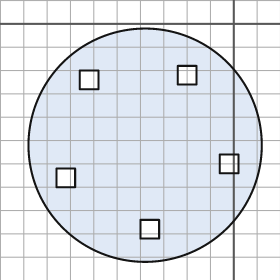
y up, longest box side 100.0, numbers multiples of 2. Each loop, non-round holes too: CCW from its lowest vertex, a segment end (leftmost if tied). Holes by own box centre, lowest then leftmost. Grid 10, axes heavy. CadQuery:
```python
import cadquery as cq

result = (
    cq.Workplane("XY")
    .moveTo(-38.0, -52.0)
    .circle(50.0)
    .moveTo(-40.0, -92.0)
    .lineTo(-32.0, -92.0)
    .lineTo(-32.0, -84.0)
    .lineTo(-40.0, -84.0)
    .close()
    .moveTo(-76.0, -70.0)
    .lineTo(-68.0, -70.0)
    .lineTo(-68.0, -62.0)
    .lineTo(-76.0, -62.0)
    .close()
    .moveTo(-6.0, -64.0)
    .lineTo(2.0, -64.0)
    .lineTo(2.0, -56.0)
    .lineTo(-6.0, -56.0)
    .close()
    .moveTo(-66.0, -28.0)
    .lineTo(-58.0, -28.0)
    .lineTo(-58.0, -20.0)
    .lineTo(-66.0, -20.0)
    .close()
    .moveTo(-24.0, -26.0)
    .lineTo(-16.0, -26.0)
    .lineTo(-16.0, -18.0)
    .lineTo(-24.0, -18.0)
    .close()
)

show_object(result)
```